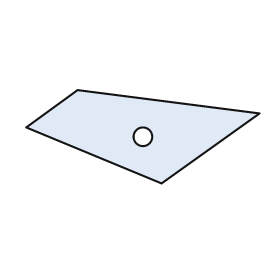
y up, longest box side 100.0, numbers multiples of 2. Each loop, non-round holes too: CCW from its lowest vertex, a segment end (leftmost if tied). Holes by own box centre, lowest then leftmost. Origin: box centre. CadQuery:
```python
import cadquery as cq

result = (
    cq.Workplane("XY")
    .moveTo(8.0, -20.0)
    .lineTo(50.0, 10.0)
    .lineTo(-28.0, 20.0)
    .lineTo(-50.0, 4.0)
    .close()
    .moveTo(0.0, 0.0)
    .circle(4.0)
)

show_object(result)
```